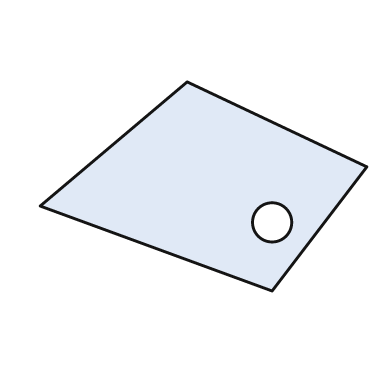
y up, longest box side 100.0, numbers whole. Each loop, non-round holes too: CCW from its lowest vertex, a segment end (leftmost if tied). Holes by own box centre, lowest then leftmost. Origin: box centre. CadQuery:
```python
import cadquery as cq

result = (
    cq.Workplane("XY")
    .moveTo(21.0, -32.0)
    .lineTo(50.0, 6.0)
    .lineTo(-5.0, 32.0)
    .lineTo(-50.0, -6.0)
    .close()
    .moveTo(21.0, -11.0)
    .circle(6.0)
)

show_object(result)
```